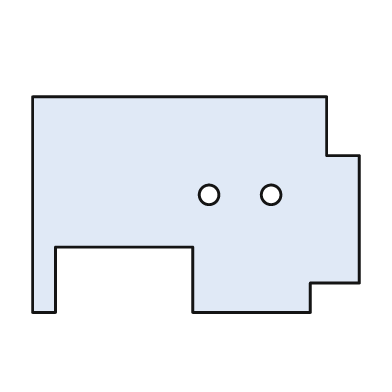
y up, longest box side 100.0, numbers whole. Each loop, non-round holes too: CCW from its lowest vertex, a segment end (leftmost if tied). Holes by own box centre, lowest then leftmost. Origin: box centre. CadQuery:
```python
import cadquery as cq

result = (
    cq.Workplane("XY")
    .moveTo(-50.0, -33.0)
    .lineTo(-43.0, -33.0)
    .lineTo(-43.0, -13.0)
    .lineTo(-1.0, -13.0)
    .lineTo(-1.0, -33.0)
    .lineTo(35.0, -33.0)
    .lineTo(35.0, -24.0)
    .lineTo(50.0, -24.0)
    .lineTo(50.0, 15.0)
    .lineTo(40.0, 15.0)
    .lineTo(40.0, 33.0)
    .lineTo(-50.0, 33.0)
    .close()
    .moveTo(4.0, 3.0)
    .circle(3.0)
    .moveTo(23.0, 3.0)
    .circle(3.0)
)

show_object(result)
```